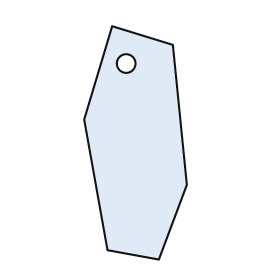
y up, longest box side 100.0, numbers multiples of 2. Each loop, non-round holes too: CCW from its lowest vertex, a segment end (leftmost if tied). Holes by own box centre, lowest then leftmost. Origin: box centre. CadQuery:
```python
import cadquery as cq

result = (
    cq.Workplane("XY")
    .moveTo(10.0, -50.0)
    .lineTo(22.0, -18.0)
    .lineTo(16.0, 42.0)
    .lineTo(-10.0, 50.0)
    .lineTo(-22.0, 10.0)
    .lineTo(-12.0, -46.0)
    .close()
    .moveTo(-4.0, 34.0)
    .circle(4.0)
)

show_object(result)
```